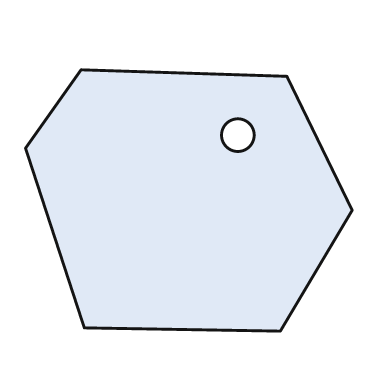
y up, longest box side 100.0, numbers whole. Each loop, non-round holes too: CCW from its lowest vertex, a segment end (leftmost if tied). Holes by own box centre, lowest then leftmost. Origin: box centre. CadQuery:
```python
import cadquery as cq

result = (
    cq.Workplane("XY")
    .moveTo(28.0, -40.0)
    .lineTo(50.0, -3.0)
    .lineTo(30.0, 38.0)
    .lineTo(-33.0, 40.0)
    .lineTo(-50.0, 16.0)
    .lineTo(-32.0, -39.0)
    .close()
    .moveTo(15.0, 20.0)
    .circle(5.0)
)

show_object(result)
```